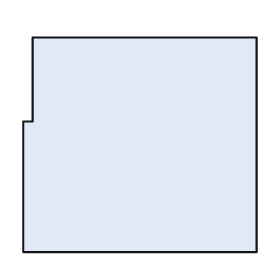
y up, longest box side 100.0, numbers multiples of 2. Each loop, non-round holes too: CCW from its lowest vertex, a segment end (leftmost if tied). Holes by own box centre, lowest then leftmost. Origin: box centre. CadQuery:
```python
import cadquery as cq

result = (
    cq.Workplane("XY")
    .moveTo(-50.0, -46.0)
    .lineTo(50.0, -46.0)
    .lineTo(50.0, 46.0)
    .lineTo(-46.0, 46.0)
    .lineTo(-46.0, 10.0)
    .lineTo(-50.0, 10.0)
    .close()
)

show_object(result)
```